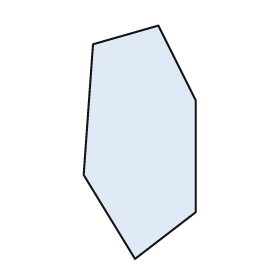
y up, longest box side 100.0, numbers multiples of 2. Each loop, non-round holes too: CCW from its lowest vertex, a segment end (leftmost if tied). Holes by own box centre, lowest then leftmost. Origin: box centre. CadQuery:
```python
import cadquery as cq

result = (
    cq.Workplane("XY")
    .moveTo(-2.0, -50.0)
    .lineTo(24.0, -30.0)
    .lineTo(24.0, 18.0)
    .lineTo(8.0, 50.0)
    .lineTo(-20.0, 42.0)
    .lineTo(-24.0, -14.0)
    .close()
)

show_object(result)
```